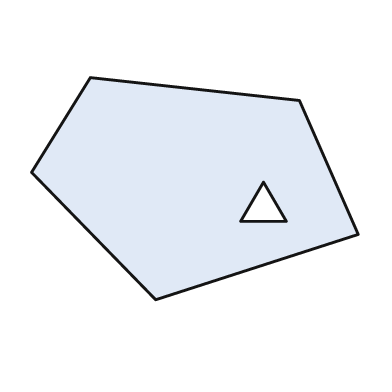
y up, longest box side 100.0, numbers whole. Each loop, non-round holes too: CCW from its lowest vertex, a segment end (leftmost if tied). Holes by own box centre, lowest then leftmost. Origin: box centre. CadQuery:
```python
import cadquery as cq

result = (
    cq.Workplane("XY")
    .moveTo(-12.0, -34.0)
    .lineTo(50.0, -14.0)
    .lineTo(32.0, 27.0)
    .lineTo(-32.0, 34.0)
    .lineTo(-50.0, 5.0)
    .close()
    .moveTo(14.0, -10.0)
    .lineTo(28.0, -10.0)
    .lineTo(21.0, 2.0)
    .close()
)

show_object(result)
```